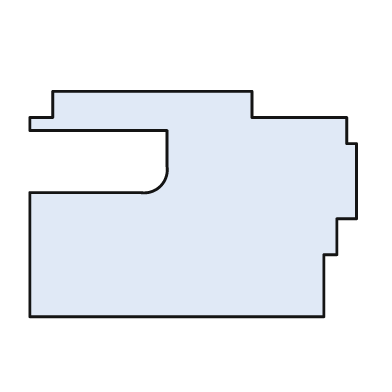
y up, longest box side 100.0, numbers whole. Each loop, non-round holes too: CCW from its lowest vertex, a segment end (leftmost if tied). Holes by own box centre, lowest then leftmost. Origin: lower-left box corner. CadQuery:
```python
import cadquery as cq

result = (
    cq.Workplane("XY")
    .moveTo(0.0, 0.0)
    .lineTo(90.0, 0.0)
    .lineTo(90.0, 19.0)
    .lineTo(94.0, 19.0)
    .lineTo(94.0, 30.0)
    .lineTo(100.0, 30.0)
    .lineTo(100.0, 53.0)
    .lineTo(97.0, 53.0)
    .lineTo(97.0, 61.0)
    .lineTo(68.0, 61.0)
    .lineTo(68.0, 69.0)
    .lineTo(7.0, 69.0)
    .lineTo(7.0, 61.0)
    .lineTo(0.0, 61.0)
    .lineTo(0.0, 57.0)
    .lineTo(42.0, 57.0)
    .lineTo(42.0, 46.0)
    .threePointArc((40.0, 40.0), (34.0, 38.0))
    .lineTo(0.0, 38.0)
    .close()
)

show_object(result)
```